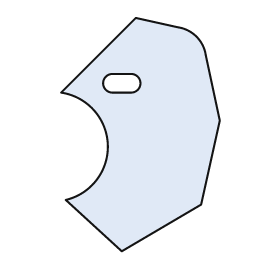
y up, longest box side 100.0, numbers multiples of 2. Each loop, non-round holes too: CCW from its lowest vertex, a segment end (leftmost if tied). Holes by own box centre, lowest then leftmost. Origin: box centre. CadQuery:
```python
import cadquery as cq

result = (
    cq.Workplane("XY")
    .moveTo(-8.0, -50.0)
    .lineTo(26.0, -30.0)
    .lineTo(34.0, 6.0)
    .lineTo(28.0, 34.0)
    .threePointArc((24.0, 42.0), (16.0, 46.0))
    .lineTo(-2.0, 50.0)
    .lineTo(-34.0, 18.0)
    .threePointArc((-14.0, -4.0), (-32.0, -28.0))
    .close()
    .moveTo(-12.0, 18.0)
    .lineTo(-4.0, 18.0)
    .threePointArc((0.0, 22.0), (-4.0, 26.0))
    .lineTo(-12.0, 26.0)
    .threePointArc((-16.0, 22.0), (-12.0, 18.0))
    .close()
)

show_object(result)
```